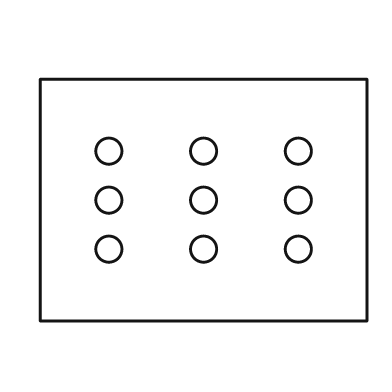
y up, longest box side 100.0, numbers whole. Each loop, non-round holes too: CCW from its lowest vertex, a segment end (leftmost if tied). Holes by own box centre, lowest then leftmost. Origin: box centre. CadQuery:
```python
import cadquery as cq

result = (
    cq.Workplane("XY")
    .moveTo(-50.0, -37.0)
    .lineTo(50.0, -37.0)
    .lineTo(50.0, 37.0)
    .lineTo(-50.0, 37.0)
    .close()
    .moveTo(-29.0, -15.0)
    .circle(4.0)
    .moveTo(0.0, -15.0)
    .circle(4.0)
    .moveTo(29.0, -15.0)
    .circle(4.0)
    .moveTo(-29.0, 0.0)
    .circle(4.0)
    .moveTo(0.0, 0.0)
    .circle(4.0)
    .moveTo(29.0, 0.0)
    .circle(4.0)
    .moveTo(-29.0, 15.0)
    .circle(4.0)
    .moveTo(0.0, 15.0)
    .circle(4.0)
    .moveTo(29.0, 15.0)
    .circle(4.0)
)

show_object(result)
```